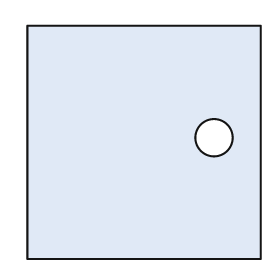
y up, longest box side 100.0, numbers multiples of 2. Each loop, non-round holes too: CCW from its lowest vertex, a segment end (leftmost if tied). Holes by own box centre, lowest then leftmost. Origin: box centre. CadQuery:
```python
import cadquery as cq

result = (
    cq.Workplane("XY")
    .moveTo(-50.0, -50.0)
    .lineTo(50.0, -50.0)
    .lineTo(50.0, 50.0)
    .lineTo(-50.0, 50.0)
    .close()
    .moveTo(30.0, 2.0)
    .circle(8.0)
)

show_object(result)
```